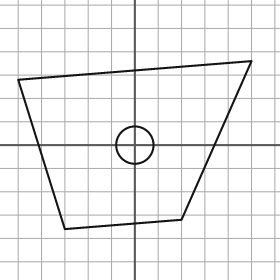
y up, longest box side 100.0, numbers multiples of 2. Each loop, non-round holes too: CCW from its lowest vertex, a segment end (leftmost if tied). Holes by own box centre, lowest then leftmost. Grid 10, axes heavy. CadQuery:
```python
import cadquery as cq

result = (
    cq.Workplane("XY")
    .moveTo(-30.0, -36.0)
    .lineTo(20.0, -32.0)
    .lineTo(50.0, 36.0)
    .lineTo(-50.0, 28.0)
    .close()
    .moveTo(0.0, 0.0)
    .circle(8.0)
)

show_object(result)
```